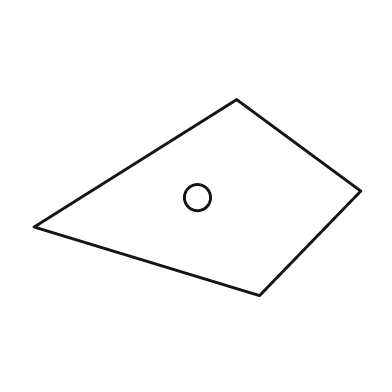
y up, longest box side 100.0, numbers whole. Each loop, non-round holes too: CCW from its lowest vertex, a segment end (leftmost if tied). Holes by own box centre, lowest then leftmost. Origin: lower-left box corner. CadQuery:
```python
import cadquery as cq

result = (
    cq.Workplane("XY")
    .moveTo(69.0, 0.0)
    .lineTo(100.0, 32.0)
    .lineTo(62.0, 60.0)
    .lineTo(0.0, 21.0)
    .close()
    .moveTo(50.0, 30.0)
    .circle(4.0)
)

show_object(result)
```